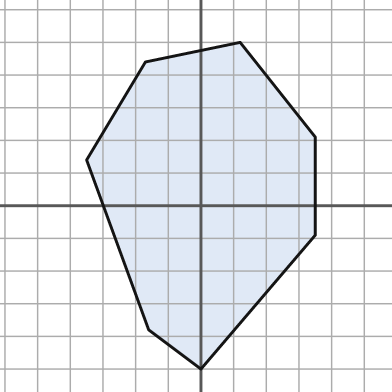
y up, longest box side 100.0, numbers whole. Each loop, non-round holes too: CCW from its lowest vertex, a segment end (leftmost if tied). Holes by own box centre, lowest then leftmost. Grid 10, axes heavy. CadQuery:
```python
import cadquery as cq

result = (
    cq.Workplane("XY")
    .moveTo(0.0, -50.0)
    .lineTo(35.0, -9.0)
    .lineTo(35.0, 21.0)
    .lineTo(12.0, 50.0)
    .lineTo(-17.0, 44.0)
    .lineTo(-35.0, 14.0)
    .lineTo(-16.0, -38.0)
    .close()
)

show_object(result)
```